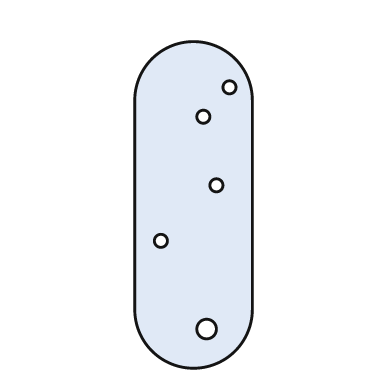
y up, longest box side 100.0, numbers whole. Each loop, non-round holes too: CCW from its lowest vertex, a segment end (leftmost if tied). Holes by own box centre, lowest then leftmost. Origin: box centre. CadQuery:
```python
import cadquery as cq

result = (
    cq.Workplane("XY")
    .moveTo(-18.0, -32.0)
    .threePointArc((0.0, -50.0), (18.0, -32.0))
    .lineTo(18.0, 32.0)
    .threePointArc((0.0, 50.0), (-18.0, 32.0))
    .close()
    .moveTo(4.0, -38.0)
    .circle(3.0)
    .moveTo(-10.0, -11.0)
    .circle(2.0)
    .moveTo(7.0, 6.0)
    .circle(2.0)
    .moveTo(3.0, 27.0)
    .circle(2.0)
    .moveTo(11.0, 36.0)
    .circle(2.0)
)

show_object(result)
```